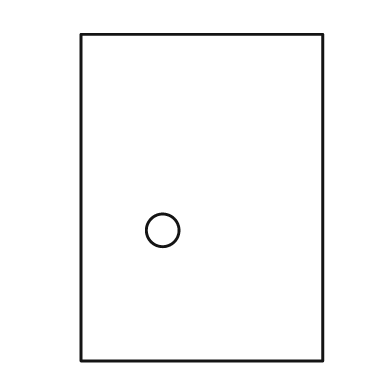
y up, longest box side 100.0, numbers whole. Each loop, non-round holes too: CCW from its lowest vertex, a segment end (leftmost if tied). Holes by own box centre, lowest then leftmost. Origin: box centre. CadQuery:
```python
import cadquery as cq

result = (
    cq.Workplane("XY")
    .moveTo(-37.0, -50.0)
    .lineTo(37.0, -50.0)
    .lineTo(37.0, 50.0)
    .lineTo(-37.0, 50.0)
    .close()
    .moveTo(-12.0, -10.0)
    .circle(5.0)
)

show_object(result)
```